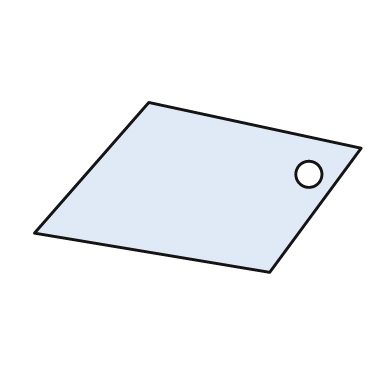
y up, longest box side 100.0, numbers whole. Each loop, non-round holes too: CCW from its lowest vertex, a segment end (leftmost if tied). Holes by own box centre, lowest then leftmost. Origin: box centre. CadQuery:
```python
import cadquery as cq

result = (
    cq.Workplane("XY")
    .moveTo(22.0, -26.0)
    .lineTo(50.0, 12.0)
    .lineTo(-15.0, 26.0)
    .lineTo(-50.0, -14.0)
    .close()
    .moveTo(34.0, 4.0)
    .circle(4.0)
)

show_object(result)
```